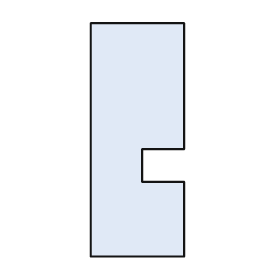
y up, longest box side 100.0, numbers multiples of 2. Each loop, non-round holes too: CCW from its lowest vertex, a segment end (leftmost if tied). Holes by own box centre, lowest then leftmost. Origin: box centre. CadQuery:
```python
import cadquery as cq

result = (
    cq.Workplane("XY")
    .moveTo(-20.0, -50.0)
    .lineTo(20.0, -50.0)
    .lineTo(20.0, -18.0)
    .lineTo(2.0, -18.0)
    .lineTo(2.0, -4.0)
    .lineTo(20.0, -4.0)
    .lineTo(20.0, 50.0)
    .lineTo(-20.0, 50.0)
    .close()
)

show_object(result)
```